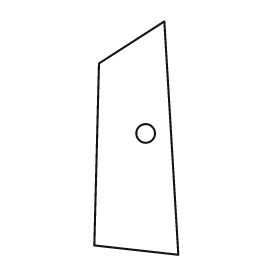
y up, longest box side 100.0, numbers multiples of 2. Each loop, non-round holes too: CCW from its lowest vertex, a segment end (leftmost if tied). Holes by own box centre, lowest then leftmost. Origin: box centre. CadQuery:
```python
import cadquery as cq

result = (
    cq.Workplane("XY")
    .moveTo(18.0, -50.0)
    .lineTo(12.0, 50.0)
    .lineTo(-16.0, 32.0)
    .lineTo(-18.0, -46.0)
    .close()
    .moveTo(4.0, 2.0)
    .circle(4.0)
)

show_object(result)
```